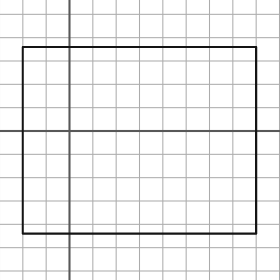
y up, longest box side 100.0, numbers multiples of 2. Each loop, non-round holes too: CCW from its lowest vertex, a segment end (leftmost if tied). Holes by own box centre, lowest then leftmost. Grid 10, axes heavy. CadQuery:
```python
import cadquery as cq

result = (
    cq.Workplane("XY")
    .moveTo(-20.0, -44.0)
    .lineTo(80.0, -44.0)
    .lineTo(80.0, 36.0)
    .lineTo(-20.0, 36.0)
    .close()
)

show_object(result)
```